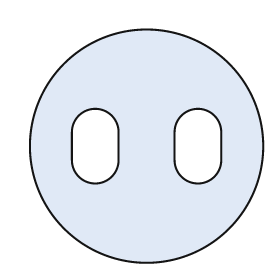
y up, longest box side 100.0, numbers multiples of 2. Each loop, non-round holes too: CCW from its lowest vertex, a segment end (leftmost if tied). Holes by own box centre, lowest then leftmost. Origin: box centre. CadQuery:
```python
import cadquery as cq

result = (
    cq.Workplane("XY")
    .moveTo(0.0, 0.0)
    .circle(50.0)
    .moveTo(-32.0, -6.0)
    .threePointArc((-22.0, -16.0), (-12.0, -6.0))
    .lineTo(-12.0, 6.0)
    .threePointArc((-22.0, 16.0), (-32.0, 6.0))
    .close()
    .moveTo(12.0, -6.0)
    .threePointArc((22.0, -16.0), (32.0, -6.0))
    .lineTo(32.0, 6.0)
    .threePointArc((22.0, 16.0), (12.0, 6.0))
    .close()
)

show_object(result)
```